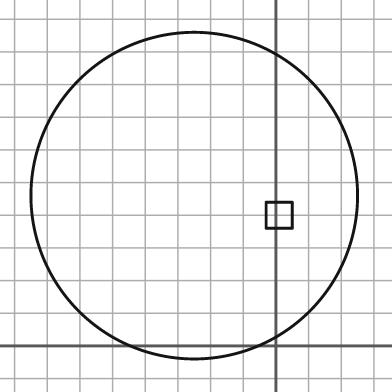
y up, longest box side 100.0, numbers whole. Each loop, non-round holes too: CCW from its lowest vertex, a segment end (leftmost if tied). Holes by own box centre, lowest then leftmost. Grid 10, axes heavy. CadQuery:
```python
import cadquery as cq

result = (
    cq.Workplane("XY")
    .moveTo(-25.0, 46.0)
    .circle(50.0)
    .moveTo(-3.0, 36.0)
    .lineTo(5.0, 36.0)
    .lineTo(5.0, 44.0)
    .lineTo(-3.0, 44.0)
    .close()
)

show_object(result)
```